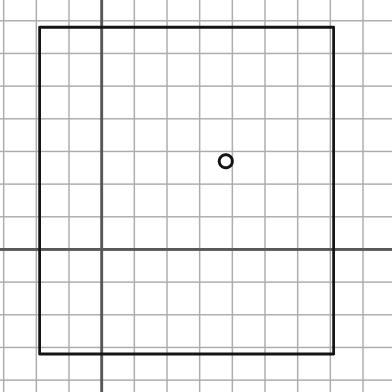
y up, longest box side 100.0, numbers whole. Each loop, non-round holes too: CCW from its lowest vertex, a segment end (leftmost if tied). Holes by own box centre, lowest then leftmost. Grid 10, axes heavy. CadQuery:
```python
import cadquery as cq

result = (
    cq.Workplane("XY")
    .moveTo(-19.0, -32.0)
    .lineTo(71.0, -32.0)
    .lineTo(71.0, 68.0)
    .lineTo(-19.0, 68.0)
    .close()
    .moveTo(38.0, 27.0)
    .circle(2.0)
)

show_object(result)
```